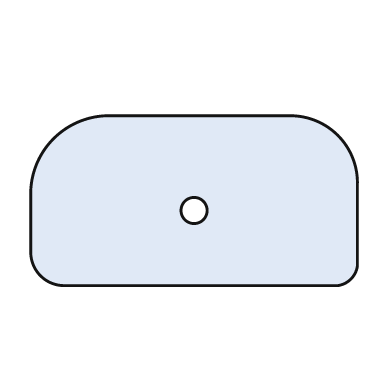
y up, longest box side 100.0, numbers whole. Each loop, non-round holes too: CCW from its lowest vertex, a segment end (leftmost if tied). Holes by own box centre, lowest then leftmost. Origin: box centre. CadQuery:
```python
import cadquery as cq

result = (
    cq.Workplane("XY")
    .moveTo(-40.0, -26.0)
    .lineTo(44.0, -26.0)
    .threePointArc((48.0, -24.0), (50.0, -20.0))
    .lineTo(50.0, 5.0)
    .threePointArc((44.0, 20.0), (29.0, 26.0))
    .lineTo(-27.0, 26.0)
    .threePointArc((-43.0, 19.0), (-50.0, 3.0))
    .lineTo(-50.0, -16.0)
    .threePointArc((-47.0, -23.0), (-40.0, -26.0))
    .close()
    .moveTo(0.0, -3.0)
    .circle(4.0)
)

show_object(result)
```